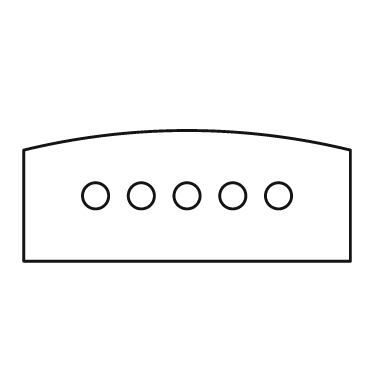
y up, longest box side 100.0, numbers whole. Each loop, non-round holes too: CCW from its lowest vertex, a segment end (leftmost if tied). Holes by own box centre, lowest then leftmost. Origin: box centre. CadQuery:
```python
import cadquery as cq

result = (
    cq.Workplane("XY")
    .moveTo(-50.0, -20.0)
    .lineTo(50.0, -20.0)
    .lineTo(50.0, 14.0)
    .threePointArc((0.0, 20.0), (-50.0, 14.0))
    .close()
    .moveTo(-28.0, 0.0)
    .circle(4.0)
    .moveTo(-14.0, 0.0)
    .circle(4.0)
    .moveTo(0.0, 0.0)
    .circle(4.0)
    .moveTo(14.0, 0.0)
    .circle(4.0)
    .moveTo(28.0, 0.0)
    .circle(4.0)
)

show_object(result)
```